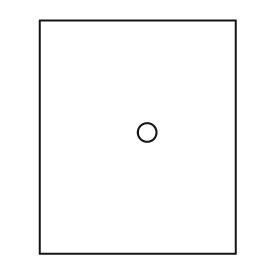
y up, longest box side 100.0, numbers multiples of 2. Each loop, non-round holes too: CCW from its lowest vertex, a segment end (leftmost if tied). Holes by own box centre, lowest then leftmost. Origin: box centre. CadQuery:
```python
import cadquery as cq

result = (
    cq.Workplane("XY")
    .moveTo(-42.0, -50.0)
    .lineTo(42.0, -50.0)
    .lineTo(42.0, 50.0)
    .lineTo(-42.0, 50.0)
    .close()
    .moveTo(4.0, 2.0)
    .circle(4.0)
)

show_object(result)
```